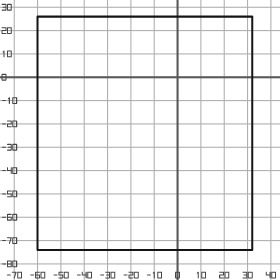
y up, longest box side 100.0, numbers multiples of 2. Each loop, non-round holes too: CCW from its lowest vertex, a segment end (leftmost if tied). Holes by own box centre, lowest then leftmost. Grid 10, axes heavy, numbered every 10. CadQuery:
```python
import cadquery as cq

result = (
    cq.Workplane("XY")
    .moveTo(-60.0, -74.0)
    .lineTo(32.0, -74.0)
    .lineTo(32.0, 26.0)
    .lineTo(-60.0, 26.0)
    .close()
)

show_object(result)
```